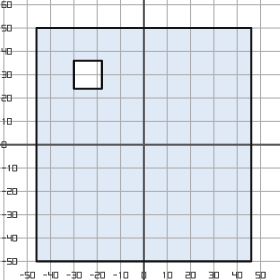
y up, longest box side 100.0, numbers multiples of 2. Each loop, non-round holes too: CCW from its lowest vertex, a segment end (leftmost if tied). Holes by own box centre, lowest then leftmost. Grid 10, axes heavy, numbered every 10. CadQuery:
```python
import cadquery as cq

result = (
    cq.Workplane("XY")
    .moveTo(-46.0, -50.0)
    .lineTo(46.0, -50.0)
    .lineTo(46.0, 50.0)
    .lineTo(-46.0, 50.0)
    .close()
    .moveTo(-30.0, 24.0)
    .lineTo(-18.0, 24.0)
    .lineTo(-18.0, 36.0)
    .lineTo(-30.0, 36.0)
    .close()
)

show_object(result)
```